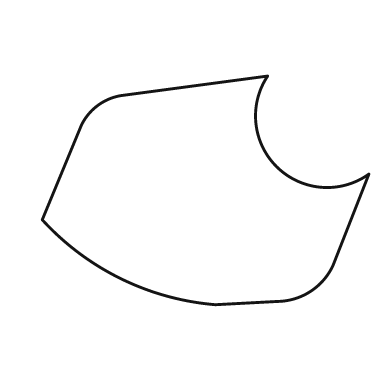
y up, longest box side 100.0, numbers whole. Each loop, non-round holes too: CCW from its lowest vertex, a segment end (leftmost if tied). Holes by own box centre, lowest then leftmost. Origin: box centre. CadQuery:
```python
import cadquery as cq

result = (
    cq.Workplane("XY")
    .moveTo(3.0, -35.0)
    .lineTo(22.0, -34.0)
    .threePointArc((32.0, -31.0), (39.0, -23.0))
    .lineTo(50.0, 5.0)
    .threePointArc((22.0, 7.0), (19.0, 35.0))
    .lineTo(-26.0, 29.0)
    .threePointArc((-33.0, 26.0), (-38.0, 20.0))
    .lineTo(-50.0, -9.0)
    .threePointArc((-26.0, -27.0), (3.0, -35.0))
    .close()
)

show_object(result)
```